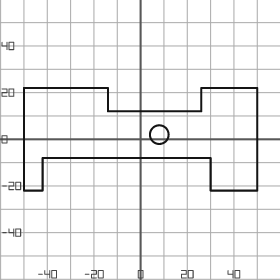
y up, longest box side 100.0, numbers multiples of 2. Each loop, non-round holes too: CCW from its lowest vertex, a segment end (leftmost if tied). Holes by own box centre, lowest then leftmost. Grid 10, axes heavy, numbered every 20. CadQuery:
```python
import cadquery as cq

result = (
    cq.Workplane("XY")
    .moveTo(-50.0, -22.0)
    .lineTo(-42.0, -22.0)
    .lineTo(-42.0, -8.0)
    .lineTo(30.0, -8.0)
    .lineTo(30.0, -22.0)
    .lineTo(50.0, -22.0)
    .lineTo(50.0, 22.0)
    .lineTo(26.0, 22.0)
    .lineTo(26.0, 12.0)
    .lineTo(-14.0, 12.0)
    .lineTo(-14.0, 22.0)
    .lineTo(-50.0, 22.0)
    .close()
    .moveTo(8.0, 2.0)
    .circle(4.0)
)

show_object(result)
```